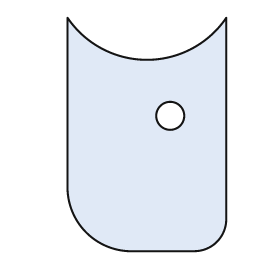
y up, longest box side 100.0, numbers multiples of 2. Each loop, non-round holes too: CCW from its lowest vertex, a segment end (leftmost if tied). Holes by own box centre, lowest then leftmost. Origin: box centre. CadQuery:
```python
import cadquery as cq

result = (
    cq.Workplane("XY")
    .moveTo(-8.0, -50.0)
    .lineTo(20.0, -50.0)
    .threePointArc((30.0, -46.0), (34.0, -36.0))
    .lineTo(34.0, 50.0)
    .threePointArc((0.0, 32.0), (-34.0, 50.0))
    .lineTo(-34.0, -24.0)
    .threePointArc((-26.0, -42.0), (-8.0, -50.0))
    .close()
    .moveTo(10.0, 8.0)
    .circle(6.0)
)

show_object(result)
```